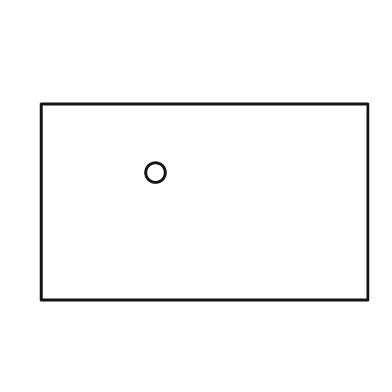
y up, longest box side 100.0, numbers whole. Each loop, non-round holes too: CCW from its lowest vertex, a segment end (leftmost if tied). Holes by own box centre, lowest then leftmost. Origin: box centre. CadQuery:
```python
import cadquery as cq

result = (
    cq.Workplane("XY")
    .moveTo(-50.0, -30.0)
    .lineTo(50.0, -30.0)
    .lineTo(50.0, 30.0)
    .lineTo(-50.0, 30.0)
    .close()
    .moveTo(-15.0, 9.0)
    .circle(3.0)
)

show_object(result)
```